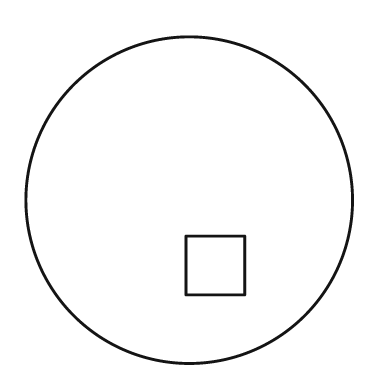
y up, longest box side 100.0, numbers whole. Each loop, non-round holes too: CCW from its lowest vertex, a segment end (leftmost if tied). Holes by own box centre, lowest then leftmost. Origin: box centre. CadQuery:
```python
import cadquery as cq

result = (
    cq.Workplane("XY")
    .moveTo(0.0, 0.0)
    .circle(50.0)
    .moveTo(-1.0, -29.0)
    .lineTo(17.0, -29.0)
    .lineTo(17.0, -11.0)
    .lineTo(-1.0, -11.0)
    .close()
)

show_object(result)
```